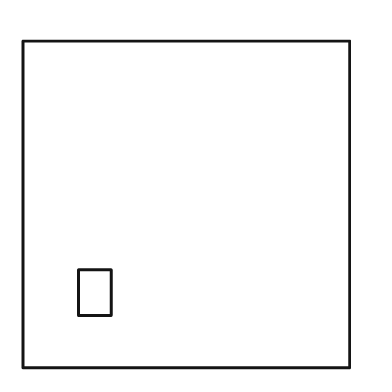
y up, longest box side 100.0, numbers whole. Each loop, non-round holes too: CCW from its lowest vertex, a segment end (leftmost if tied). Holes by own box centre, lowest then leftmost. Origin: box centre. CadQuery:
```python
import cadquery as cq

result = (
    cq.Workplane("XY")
    .moveTo(-50.0, -50.0)
    .lineTo(50.0, -50.0)
    .lineTo(50.0, 50.0)
    .lineTo(-50.0, 50.0)
    .close()
    .moveTo(-33.0, -34.0)
    .lineTo(-23.0, -34.0)
    .lineTo(-23.0, -20.0)
    .lineTo(-33.0, -20.0)
    .close()
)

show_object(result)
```